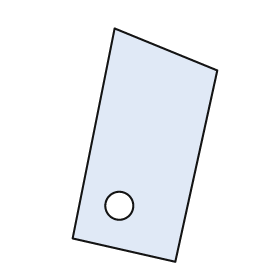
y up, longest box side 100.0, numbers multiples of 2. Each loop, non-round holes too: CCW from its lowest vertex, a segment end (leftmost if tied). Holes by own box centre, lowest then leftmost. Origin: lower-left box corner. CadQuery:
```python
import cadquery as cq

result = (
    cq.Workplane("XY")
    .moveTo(44.0, 0.0)
    .lineTo(62.0, 82.0)
    .lineTo(18.0, 100.0)
    .lineTo(0.0, 10.0)
    .close()
    .moveTo(20.0, 24.0)
    .circle(6.0)
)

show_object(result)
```